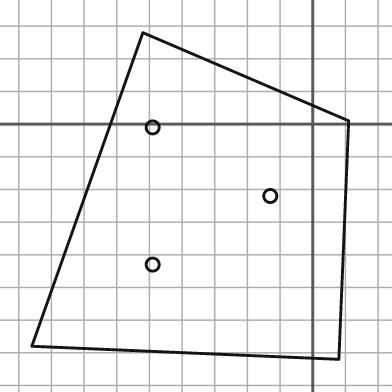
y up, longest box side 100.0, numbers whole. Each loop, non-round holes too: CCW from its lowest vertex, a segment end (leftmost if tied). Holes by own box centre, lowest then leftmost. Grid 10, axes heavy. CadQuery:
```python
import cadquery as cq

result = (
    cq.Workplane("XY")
    .moveTo(8.0, -72.0)
    .lineTo(11.0, 1.0)
    .lineTo(-52.0, 28.0)
    .lineTo(-86.0, -68.0)
    .close()
    .moveTo(-49.0, -43.0)
    .circle(2.0)
    .moveTo(-13.0, -22.0)
    .circle(2.0)
    .moveTo(-49.0, -1.0)
    .circle(2.0)
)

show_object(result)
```